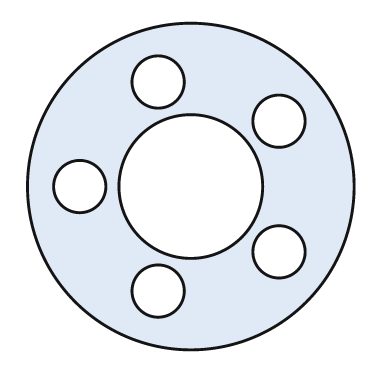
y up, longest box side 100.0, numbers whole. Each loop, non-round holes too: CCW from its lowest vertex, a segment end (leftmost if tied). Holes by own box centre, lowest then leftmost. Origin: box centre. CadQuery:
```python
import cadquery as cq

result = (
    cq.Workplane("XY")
    .moveTo(0.0, 0.0)
    .circle(50.0)
    .moveTo(-10.0, -32.0)
    .circle(8.0)
    .moveTo(27.0, -20.0)
    .circle(8.0)
    .moveTo(-34.0, 0.0)
    .circle(8.0)
    .moveTo(0.0, 0.0)
    .circle(22.0)
    .moveTo(27.0, 20.0)
    .circle(8.0)
    .moveTo(-10.0, 32.0)
    .circle(8.0)
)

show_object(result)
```